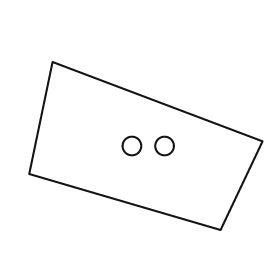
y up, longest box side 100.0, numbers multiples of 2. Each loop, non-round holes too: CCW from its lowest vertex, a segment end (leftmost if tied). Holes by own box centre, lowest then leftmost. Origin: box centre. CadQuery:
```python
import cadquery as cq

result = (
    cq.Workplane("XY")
    .moveTo(32.0, -36.0)
    .lineTo(50.0, 2.0)
    .lineTo(-40.0, 36.0)
    .lineTo(-50.0, -12.0)
    .close()
    .moveTo(-6.0, 0.0)
    .circle(4.0)
    .moveTo(8.0, 0.0)
    .circle(4.0)
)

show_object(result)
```